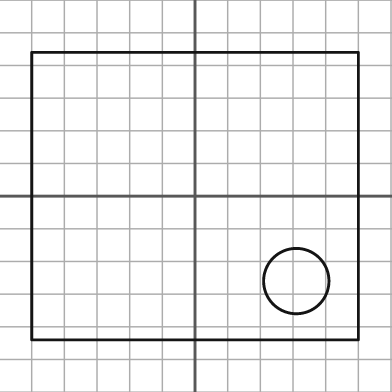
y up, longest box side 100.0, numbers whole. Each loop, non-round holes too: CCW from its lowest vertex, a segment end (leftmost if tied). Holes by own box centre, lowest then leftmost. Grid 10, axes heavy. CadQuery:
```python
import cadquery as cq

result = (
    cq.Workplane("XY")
    .moveTo(-50.0, -44.0)
    .lineTo(50.0, -44.0)
    .lineTo(50.0, 44.0)
    .lineTo(-50.0, 44.0)
    .close()
    .moveTo(31.0, -26.0)
    .circle(10.0)
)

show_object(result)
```